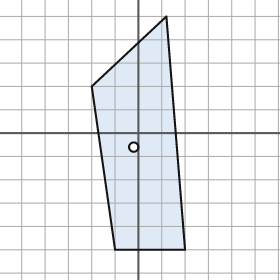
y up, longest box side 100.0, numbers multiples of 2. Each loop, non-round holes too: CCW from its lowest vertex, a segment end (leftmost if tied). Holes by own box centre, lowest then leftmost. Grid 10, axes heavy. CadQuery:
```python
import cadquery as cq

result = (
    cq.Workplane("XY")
    .moveTo(-10.0, -50.0)
    .lineTo(20.0, -50.0)
    .lineTo(12.0, 50.0)
    .lineTo(-20.0, 20.0)
    .close()
    .moveTo(-2.0, -6.0)
    .circle(2.0)
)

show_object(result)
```